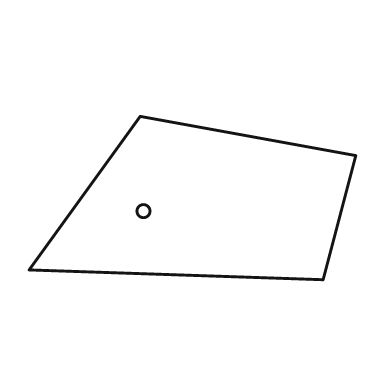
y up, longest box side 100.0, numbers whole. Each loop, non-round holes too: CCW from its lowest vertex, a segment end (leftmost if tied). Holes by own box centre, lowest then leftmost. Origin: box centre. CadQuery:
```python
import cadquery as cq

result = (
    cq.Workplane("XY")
    .moveTo(40.0, -25.0)
    .lineTo(50.0, 13.0)
    .lineTo(-16.0, 25.0)
    .lineTo(-50.0, -22.0)
    .close()
    .moveTo(-15.0, -4.0)
    .circle(2.0)
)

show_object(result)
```